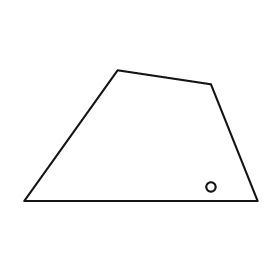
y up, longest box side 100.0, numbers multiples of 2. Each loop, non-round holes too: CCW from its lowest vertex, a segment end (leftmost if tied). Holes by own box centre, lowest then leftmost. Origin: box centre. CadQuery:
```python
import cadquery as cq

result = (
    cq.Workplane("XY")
    .moveTo(-50.0, -28.0)
    .lineTo(50.0, -28.0)
    .lineTo(30.0, 22.0)
    .lineTo(-10.0, 28.0)
    .close()
    .moveTo(30.0, -22.0)
    .circle(2.0)
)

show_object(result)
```